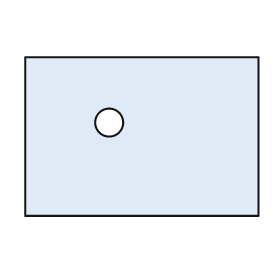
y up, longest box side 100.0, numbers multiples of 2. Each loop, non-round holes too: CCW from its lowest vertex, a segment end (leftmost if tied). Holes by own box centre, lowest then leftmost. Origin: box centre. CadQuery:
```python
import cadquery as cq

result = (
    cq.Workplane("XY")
    .moveTo(-50.0, -34.0)
    .lineTo(50.0, -34.0)
    .lineTo(50.0, 34.0)
    .lineTo(-50.0, 34.0)
    .close()
    .moveTo(-14.0, 6.0)
    .circle(6.0)
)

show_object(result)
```